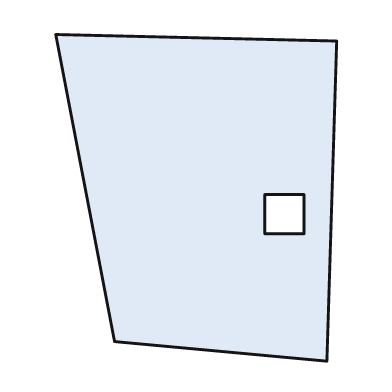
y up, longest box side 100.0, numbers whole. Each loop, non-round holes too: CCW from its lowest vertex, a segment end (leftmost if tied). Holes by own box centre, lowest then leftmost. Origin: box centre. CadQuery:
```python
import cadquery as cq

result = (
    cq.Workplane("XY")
    .moveTo(40.0, -50.0)
    .lineTo(43.0, 48.0)
    .lineTo(-43.0, 50.0)
    .lineTo(-25.0, -44.0)
    .close()
    .moveTo(21.0, -11.0)
    .lineTo(33.0, -11.0)
    .lineTo(33.0, 1.0)
    .lineTo(21.0, 1.0)
    .close()
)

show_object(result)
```